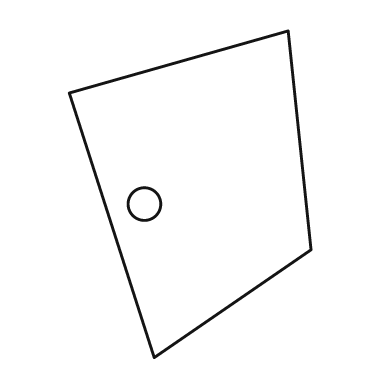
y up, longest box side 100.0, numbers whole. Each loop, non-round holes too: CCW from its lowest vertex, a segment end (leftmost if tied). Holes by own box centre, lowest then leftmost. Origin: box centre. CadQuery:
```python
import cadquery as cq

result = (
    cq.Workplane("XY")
    .moveTo(-11.0, -50.0)
    .lineTo(37.0, -17.0)
    .lineTo(30.0, 50.0)
    .lineTo(-37.0, 31.0)
    .close()
    .moveTo(-14.0, -3.0)
    .circle(5.0)
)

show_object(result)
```